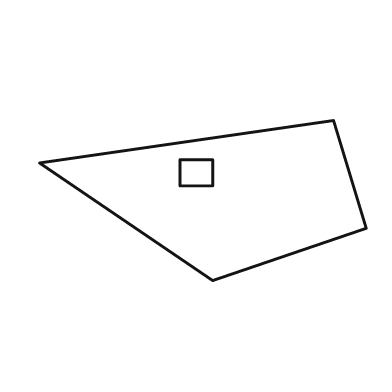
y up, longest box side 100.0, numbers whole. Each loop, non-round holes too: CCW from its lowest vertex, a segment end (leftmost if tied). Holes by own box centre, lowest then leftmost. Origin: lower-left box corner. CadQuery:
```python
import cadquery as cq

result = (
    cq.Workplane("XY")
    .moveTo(53.0, 0.0)
    .lineTo(100.0, 16.0)
    .lineTo(90.0, 49.0)
    .lineTo(0.0, 36.0)
    .close()
    .moveTo(43.0, 29.0)
    .lineTo(53.0, 29.0)
    .lineTo(53.0, 37.0)
    .lineTo(43.0, 37.0)
    .close()
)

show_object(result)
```